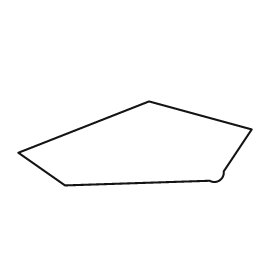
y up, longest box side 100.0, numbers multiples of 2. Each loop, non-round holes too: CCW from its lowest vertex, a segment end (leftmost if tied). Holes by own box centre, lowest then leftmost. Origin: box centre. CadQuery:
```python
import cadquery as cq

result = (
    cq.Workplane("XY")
    .moveTo(-30.0, -18.0)
    .lineTo(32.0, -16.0)
    .threePointArc((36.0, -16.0), (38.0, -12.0))
    .lineTo(50.0, 6.0)
    .lineTo(6.0, 18.0)
    .lineTo(-50.0, -4.0)
    .close()
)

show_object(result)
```